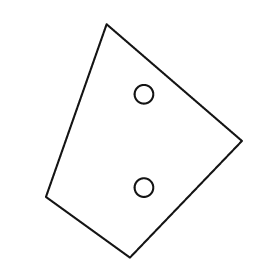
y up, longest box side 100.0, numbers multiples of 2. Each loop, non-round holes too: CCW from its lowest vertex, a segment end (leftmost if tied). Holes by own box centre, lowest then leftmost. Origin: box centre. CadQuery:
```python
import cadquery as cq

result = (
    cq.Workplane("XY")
    .moveTo(-6.0, -50.0)
    .lineTo(42.0, 0.0)
    .lineTo(-16.0, 50.0)
    .lineTo(-42.0, -24.0)
    .close()
    .moveTo(0.0, -20.0)
    .circle(4.0)
    .moveTo(0.0, 20.0)
    .circle(4.0)
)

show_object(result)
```